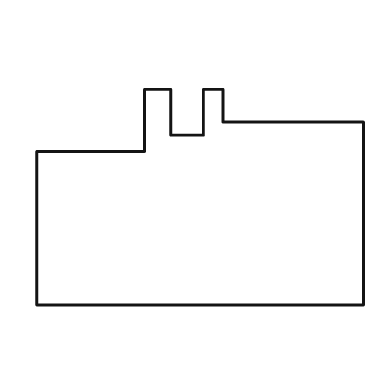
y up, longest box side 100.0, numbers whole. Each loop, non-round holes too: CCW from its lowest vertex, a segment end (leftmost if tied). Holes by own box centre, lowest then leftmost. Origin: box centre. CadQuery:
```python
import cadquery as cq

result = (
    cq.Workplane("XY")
    .moveTo(-50.0, -33.0)
    .lineTo(50.0, -33.0)
    .lineTo(50.0, 23.0)
    .lineTo(7.0, 23.0)
    .lineTo(7.0, 33.0)
    .lineTo(1.0, 33.0)
    .lineTo(1.0, 19.0)
    .lineTo(-9.0, 19.0)
    .lineTo(-9.0, 33.0)
    .lineTo(-17.0, 33.0)
    .lineTo(-17.0, 14.0)
    .lineTo(-50.0, 14.0)
    .close()
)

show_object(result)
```